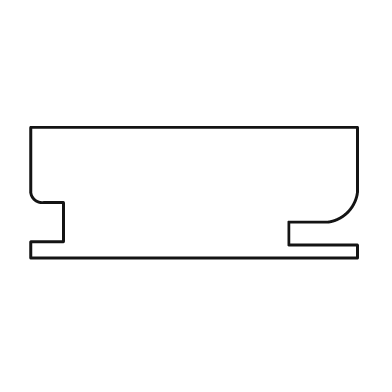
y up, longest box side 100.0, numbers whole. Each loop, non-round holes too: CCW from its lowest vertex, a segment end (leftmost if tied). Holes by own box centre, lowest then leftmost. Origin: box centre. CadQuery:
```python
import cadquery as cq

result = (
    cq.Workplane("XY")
    .moveTo(-50.0, -20.0)
    .lineTo(50.0, -20.0)
    .lineTo(50.0, -16.0)
    .lineTo(29.0, -16.0)
    .lineTo(29.0, -9.0)
    .lineTo(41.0, -9.0)
    .threePointArc((47.0, -6.0), (50.0, 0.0))
    .lineTo(50.0, 20.0)
    .lineTo(-50.0, 20.0)
    .lineTo(-50.0, 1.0)
    .threePointArc((-49.0, -2.0), (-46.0, -3.0))
    .lineTo(-40.0, -3.0)
    .lineTo(-40.0, -15.0)
    .lineTo(-50.0, -15.0)
    .close()
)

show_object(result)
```